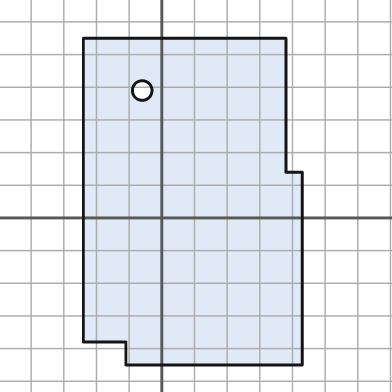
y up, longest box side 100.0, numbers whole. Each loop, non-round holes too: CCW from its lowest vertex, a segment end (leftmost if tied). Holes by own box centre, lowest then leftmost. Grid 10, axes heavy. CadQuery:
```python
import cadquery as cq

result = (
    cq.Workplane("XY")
    .moveTo(-11.0, -45.0)
    .lineTo(43.0, -45.0)
    .lineTo(43.0, 14.0)
    .lineTo(38.0, 14.0)
    .lineTo(38.0, 55.0)
    .lineTo(-24.0, 55.0)
    .lineTo(-24.0, -38.0)
    .lineTo(-11.0, -38.0)
    .close()
    .moveTo(-6.0, 39.0)
    .circle(3.0)
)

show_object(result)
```